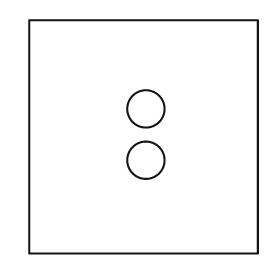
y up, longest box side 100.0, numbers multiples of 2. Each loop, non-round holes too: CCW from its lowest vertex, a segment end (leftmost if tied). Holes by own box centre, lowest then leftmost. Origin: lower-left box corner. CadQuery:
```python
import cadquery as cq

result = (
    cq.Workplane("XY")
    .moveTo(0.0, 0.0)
    .lineTo(98.0, 0.0)
    .lineTo(98.0, 100.0)
    .lineTo(0.0, 100.0)
    .close()
    .moveTo(50.0, 40.0)
    .circle(8.0)
    .moveTo(50.0, 62.0)
    .circle(8.0)
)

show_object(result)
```